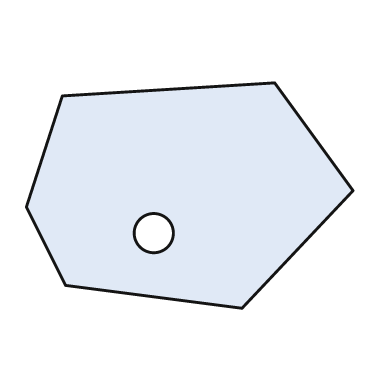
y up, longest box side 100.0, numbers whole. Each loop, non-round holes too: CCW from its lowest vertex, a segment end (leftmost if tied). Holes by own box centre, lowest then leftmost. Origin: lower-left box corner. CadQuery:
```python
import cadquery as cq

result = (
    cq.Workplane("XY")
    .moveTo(66.0, 0.0)
    .lineTo(100.0, 36.0)
    .lineTo(76.0, 69.0)
    .lineTo(11.0, 65.0)
    .lineTo(0.0, 31.0)
    .lineTo(12.0, 7.0)
    .close()
    .moveTo(39.0, 23.0)
    .circle(6.0)
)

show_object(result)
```